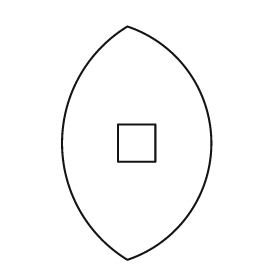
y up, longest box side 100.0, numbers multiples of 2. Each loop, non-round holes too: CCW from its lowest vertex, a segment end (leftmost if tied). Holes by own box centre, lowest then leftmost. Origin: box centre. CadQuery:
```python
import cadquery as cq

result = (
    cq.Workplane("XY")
    .moveTo(-4.0, -50.0)
    .threePointArc((32.0, 0.0), (-4.0, 50.0))
    .threePointArc((-32.0, 0.0), (-4.0, -50.0))
    .close()
    .moveTo(-8.0, -8.0)
    .lineTo(8.0, -8.0)
    .lineTo(8.0, 8.0)
    .lineTo(-8.0, 8.0)
    .close()
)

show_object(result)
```